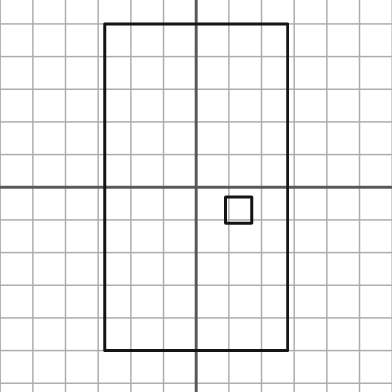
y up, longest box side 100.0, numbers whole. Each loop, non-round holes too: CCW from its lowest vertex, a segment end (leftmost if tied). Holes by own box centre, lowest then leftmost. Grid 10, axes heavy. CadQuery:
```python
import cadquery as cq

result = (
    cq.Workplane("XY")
    .moveTo(-28.0, -50.0)
    .lineTo(28.0, -50.0)
    .lineTo(28.0, 50.0)
    .lineTo(-28.0, 50.0)
    .close()
    .moveTo(9.0, -11.0)
    .lineTo(17.0, -11.0)
    .lineTo(17.0, -3.0)
    .lineTo(9.0, -3.0)
    .close()
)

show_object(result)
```